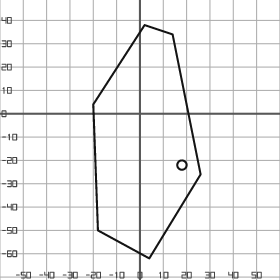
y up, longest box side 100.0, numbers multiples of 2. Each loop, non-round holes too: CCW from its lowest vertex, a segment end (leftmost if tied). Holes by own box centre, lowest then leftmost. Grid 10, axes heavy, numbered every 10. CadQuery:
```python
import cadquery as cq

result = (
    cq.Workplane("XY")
    .moveTo(4.0, -62.0)
    .lineTo(26.0, -26.0)
    .lineTo(14.0, 34.0)
    .lineTo(2.0, 38.0)
    .lineTo(-20.0, 4.0)
    .lineTo(-18.0, -50.0)
    .close()
    .moveTo(18.0, -22.0)
    .circle(2.0)
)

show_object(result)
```